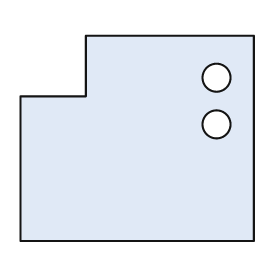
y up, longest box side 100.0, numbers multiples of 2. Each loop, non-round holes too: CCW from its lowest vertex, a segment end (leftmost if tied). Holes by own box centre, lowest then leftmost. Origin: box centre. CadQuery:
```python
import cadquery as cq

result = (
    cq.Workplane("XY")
    .moveTo(-50.0, -44.0)
    .lineTo(50.0, -44.0)
    .lineTo(50.0, 44.0)
    .lineTo(-22.0, 44.0)
    .lineTo(-22.0, 18.0)
    .lineTo(-50.0, 18.0)
    .close()
    .moveTo(34.0, 6.0)
    .circle(6.0)
    .moveTo(34.0, 26.0)
    .circle(6.0)
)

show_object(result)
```